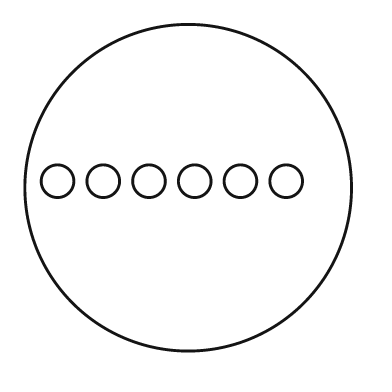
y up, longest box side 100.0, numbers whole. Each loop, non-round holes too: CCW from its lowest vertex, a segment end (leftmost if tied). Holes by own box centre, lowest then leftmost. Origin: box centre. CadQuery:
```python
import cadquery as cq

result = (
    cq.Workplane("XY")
    .moveTo(0.0, 0.0)
    .circle(50.0)
    .moveTo(-40.0, 2.0)
    .circle(5.0)
    .moveTo(-26.0, 2.0)
    .circle(5.0)
    .moveTo(-12.0, 2.0)
    .circle(5.0)
    .moveTo(2.0, 2.0)
    .circle(5.0)
    .moveTo(16.0, 2.0)
    .circle(5.0)
    .moveTo(30.0, 2.0)
    .circle(5.0)
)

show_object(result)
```